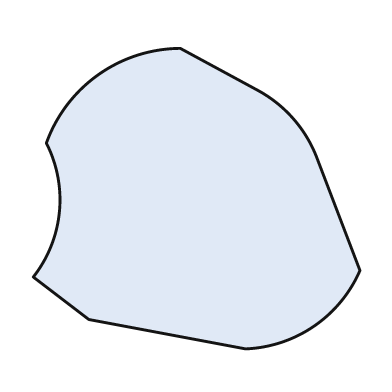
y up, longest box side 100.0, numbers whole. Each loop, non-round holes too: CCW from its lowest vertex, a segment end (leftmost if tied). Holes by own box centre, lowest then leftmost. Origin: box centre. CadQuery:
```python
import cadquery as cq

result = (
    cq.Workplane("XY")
    .moveTo(15.0, -46.0)
    .threePointArc((36.0, -39.0), (50.0, -22.0))
    .lineTo(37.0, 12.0)
    .threePointArc((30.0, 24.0), (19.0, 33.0))
    .lineTo(-5.0, 46.0)
    .threePointArc((-30.0, 38.0), (-46.0, 17.0))
    .threePointArc((-42.0, -4.0), (-50.0, -24.0))
    .lineTo(-33.0, -37.0)
    .close()
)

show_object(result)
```